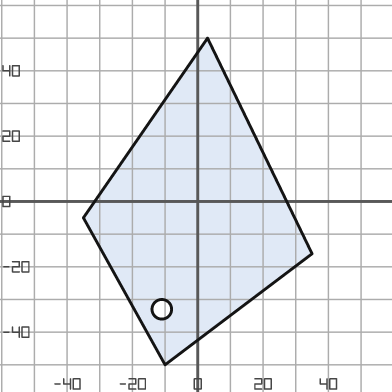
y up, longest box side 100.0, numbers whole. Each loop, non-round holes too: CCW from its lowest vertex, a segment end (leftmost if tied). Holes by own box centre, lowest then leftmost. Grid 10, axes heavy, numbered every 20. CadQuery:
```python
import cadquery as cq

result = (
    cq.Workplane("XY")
    .moveTo(-10.0, -50.0)
    .lineTo(35.0, -16.0)
    .lineTo(3.0, 50.0)
    .lineTo(-35.0, -5.0)
    .close()
    .moveTo(-11.0, -33.0)
    .circle(3.0)
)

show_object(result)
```